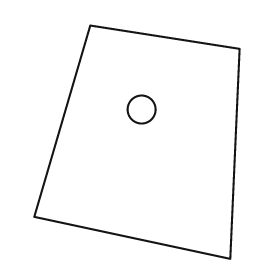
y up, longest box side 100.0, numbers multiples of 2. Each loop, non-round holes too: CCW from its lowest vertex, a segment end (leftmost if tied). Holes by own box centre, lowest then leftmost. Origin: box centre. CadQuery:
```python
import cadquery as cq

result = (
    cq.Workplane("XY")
    .moveTo(40.0, -50.0)
    .lineTo(44.0, 40.0)
    .lineTo(-20.0, 50.0)
    .lineTo(-44.0, -32.0)
    .close()
    .moveTo(2.0, 14.0)
    .circle(6.0)
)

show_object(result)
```